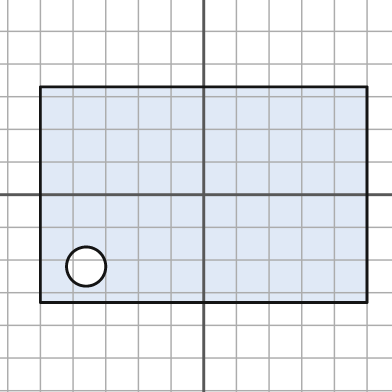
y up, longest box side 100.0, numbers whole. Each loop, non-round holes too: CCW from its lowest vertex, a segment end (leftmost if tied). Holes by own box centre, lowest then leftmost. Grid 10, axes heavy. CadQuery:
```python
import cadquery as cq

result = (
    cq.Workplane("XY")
    .moveTo(-50.0, -33.0)
    .lineTo(50.0, -33.0)
    .lineTo(50.0, 33.0)
    .lineTo(-50.0, 33.0)
    .close()
    .moveTo(-36.0, -22.0)
    .circle(6.0)
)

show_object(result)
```